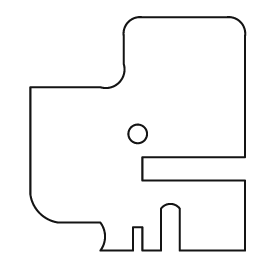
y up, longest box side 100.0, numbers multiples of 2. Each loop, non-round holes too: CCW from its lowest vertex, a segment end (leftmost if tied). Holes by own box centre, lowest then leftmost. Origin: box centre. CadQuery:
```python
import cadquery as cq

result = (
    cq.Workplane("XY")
    .moveTo(-16.0, -50.0)
    .lineTo(-2.0, -50.0)
    .lineTo(-2.0, -40.0)
    .lineTo(2.0, -40.0)
    .lineTo(2.0, -50.0)
    .lineTo(10.0, -50.0)
    .lineTo(10.0, -32.0)
    .threePointArc((14.0, -30.0), (18.0, -32.0))
    .lineTo(18.0, -50.0)
    .lineTo(46.0, -50.0)
    .lineTo(46.0, -20.0)
    .lineTo(2.0, -20.0)
    .lineTo(2.0, -10.0)
    .lineTo(46.0, -10.0)
    .lineTo(46.0, 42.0)
    .threePointArc((44.0, 48.0), (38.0, 50.0))
    .lineTo(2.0, 50.0)
    .threePointArc((-4.0, 48.0), (-6.0, 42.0))
    .lineTo(-6.0, 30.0)
    .threePointArc((-8.0, 22.0), (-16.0, 20.0))
    .lineTo(-46.0, 20.0)
    .lineTo(-46.0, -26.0)
    .threePointArc((-42.0, -34.0), (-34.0, -38.0))
    .lineTo(-16.0, -38.0)
    .threePointArc((-14.0, -44.0), (-16.0, -50.0))
    .close()
    .moveTo(0.0, 0.0)
    .circle(4.0)
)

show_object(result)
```